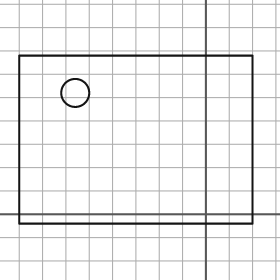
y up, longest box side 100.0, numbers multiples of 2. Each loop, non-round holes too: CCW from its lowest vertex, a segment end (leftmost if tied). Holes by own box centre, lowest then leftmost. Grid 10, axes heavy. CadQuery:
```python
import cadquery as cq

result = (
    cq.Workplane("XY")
    .moveTo(-80.0, -4.0)
    .lineTo(20.0, -4.0)
    .lineTo(20.0, 68.0)
    .lineTo(-80.0, 68.0)
    .close()
    .moveTo(-56.0, 52.0)
    .circle(6.0)
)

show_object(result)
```